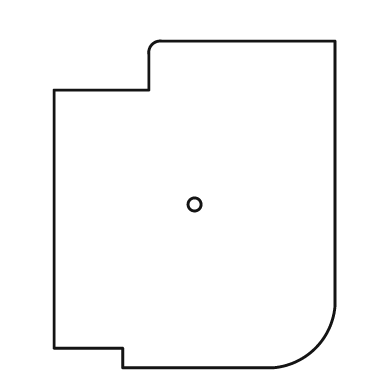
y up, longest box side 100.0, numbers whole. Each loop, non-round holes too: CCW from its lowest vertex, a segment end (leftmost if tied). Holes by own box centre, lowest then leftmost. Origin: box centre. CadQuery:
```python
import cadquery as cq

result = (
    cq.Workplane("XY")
    .moveTo(-22.0, -50.0)
    .lineTo(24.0, -50.0)
    .threePointArc((37.0, -44.0), (43.0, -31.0))
    .lineTo(43.0, 50.0)
    .lineTo(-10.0, 50.0)
    .threePointArc((-13.0, 49.0), (-14.0, 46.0))
    .lineTo(-14.0, 35.0)
    .lineTo(-43.0, 35.0)
    .lineTo(-43.0, -44.0)
    .lineTo(-22.0, -44.0)
    .close()
    .moveTo(0.0, 0.0)
    .circle(2.0)
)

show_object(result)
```